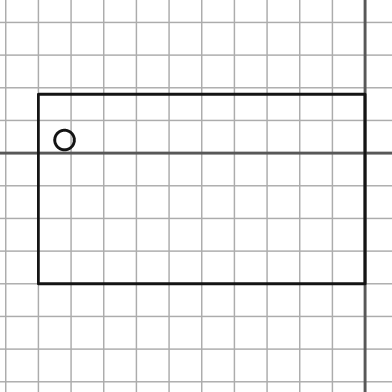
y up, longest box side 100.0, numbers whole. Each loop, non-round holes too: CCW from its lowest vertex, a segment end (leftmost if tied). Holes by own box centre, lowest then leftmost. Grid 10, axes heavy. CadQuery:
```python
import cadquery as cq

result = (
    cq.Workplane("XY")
    .moveTo(-100.0, -40.0)
    .lineTo(0.0, -40.0)
    .lineTo(0.0, 18.0)
    .lineTo(-100.0, 18.0)
    .close()
    .moveTo(-92.0, 4.0)
    .circle(3.0)
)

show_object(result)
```